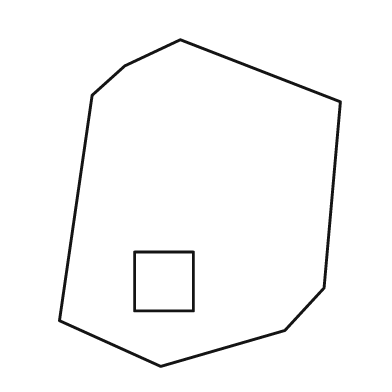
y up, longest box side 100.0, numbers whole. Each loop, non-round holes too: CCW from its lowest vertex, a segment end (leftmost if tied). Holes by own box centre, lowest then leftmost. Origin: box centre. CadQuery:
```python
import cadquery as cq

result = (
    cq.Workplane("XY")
    .moveTo(-12.0, -50.0)
    .lineTo(26.0, -39.0)
    .lineTo(38.0, -26.0)
    .lineTo(43.0, 31.0)
    .lineTo(-6.0, 50.0)
    .lineTo(-23.0, 42.0)
    .lineTo(-33.0, 33.0)
    .lineTo(-43.0, -36.0)
    .close()
    .moveTo(-20.0, -33.0)
    .lineTo(-2.0, -33.0)
    .lineTo(-2.0, -15.0)
    .lineTo(-20.0, -15.0)
    .close()
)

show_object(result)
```